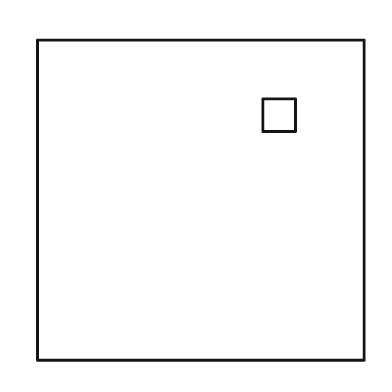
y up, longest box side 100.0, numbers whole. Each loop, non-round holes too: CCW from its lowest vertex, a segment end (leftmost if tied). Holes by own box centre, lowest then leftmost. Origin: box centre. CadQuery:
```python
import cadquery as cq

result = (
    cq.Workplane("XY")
    .moveTo(-50.0, -49.0)
    .lineTo(50.0, -49.0)
    .lineTo(50.0, 49.0)
    .lineTo(-50.0, 49.0)
    .close()
    .moveTo(19.0, 21.0)
    .lineTo(29.0, 21.0)
    .lineTo(29.0, 31.0)
    .lineTo(19.0, 31.0)
    .close()
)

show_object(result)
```